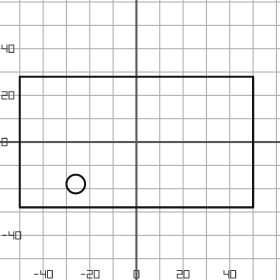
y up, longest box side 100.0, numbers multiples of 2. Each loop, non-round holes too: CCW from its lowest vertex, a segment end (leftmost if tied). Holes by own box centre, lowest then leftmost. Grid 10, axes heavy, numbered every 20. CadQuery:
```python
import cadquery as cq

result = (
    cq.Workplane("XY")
    .moveTo(-50.0, -28.0)
    .lineTo(50.0, -28.0)
    .lineTo(50.0, 28.0)
    .lineTo(-50.0, 28.0)
    .close()
    .moveTo(-26.0, -18.0)
    .circle(4.0)
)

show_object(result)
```